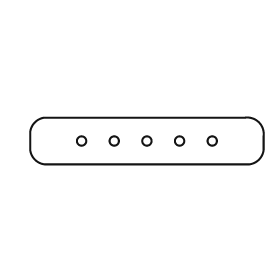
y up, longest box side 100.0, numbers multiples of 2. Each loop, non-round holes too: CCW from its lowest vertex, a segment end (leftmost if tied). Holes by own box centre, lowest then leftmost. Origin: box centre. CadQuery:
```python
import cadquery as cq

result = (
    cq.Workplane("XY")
    .moveTo(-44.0, -10.0)
    .lineTo(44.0, -10.0)
    .threePointArc((48.0, -8.0), (50.0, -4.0))
    .lineTo(50.0, 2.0)
    .threePointArc((48.0, 8.0), (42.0, 10.0))
    .lineTo(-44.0, 10.0)
    .threePointArc((-48.0, 8.0), (-50.0, 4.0))
    .lineTo(-50.0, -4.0)
    .threePointArc((-48.0, -8.0), (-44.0, -10.0))
    .close()
    .moveTo(-28.0, 0.0)
    .circle(2.0)
    .moveTo(-14.0, 0.0)
    .circle(2.0)
    .moveTo(0.0, 0.0)
    .circle(2.0)
    .moveTo(14.0, 0.0)
    .circle(2.0)
    .moveTo(28.0, 0.0)
    .circle(2.0)
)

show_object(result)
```